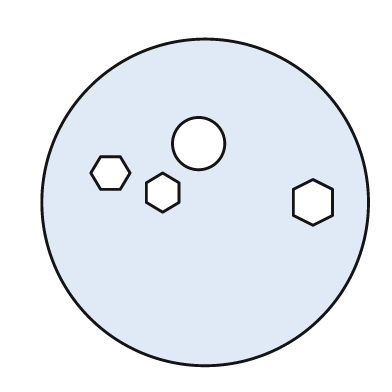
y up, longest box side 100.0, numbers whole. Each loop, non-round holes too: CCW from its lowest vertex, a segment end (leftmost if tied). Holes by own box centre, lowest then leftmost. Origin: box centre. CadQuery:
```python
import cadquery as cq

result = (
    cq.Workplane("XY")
    .moveTo(0.0, 0.0)
    .circle(50.0)
    .moveTo(33.0, -7.0)
    .lineTo(39.0, -4.0)
    .lineTo(39.0, 4.0)
    .lineTo(33.0, 7.0)
    .lineTo(27.0, 4.0)
    .lineTo(27.0, -4.0)
    .close()
    .moveTo(-13.0, -3.0)
    .lineTo(-8.0, 0.0)
    .lineTo(-8.0, 6.0)
    .lineTo(-13.0, 9.0)
    .lineTo(-18.0, 6.0)
    .lineTo(-18.0, 0.0)
    .close()
    .moveTo(-32.0, 4.0)
    .lineTo(-26.0, 4.0)
    .lineTo(-23.0, 9.0)
    .lineTo(-26.0, 14.0)
    .lineTo(-32.0, 14.0)
    .lineTo(-35.0, 9.0)
    .close()
    .moveTo(-2.0, 18.0)
    .circle(8.0)
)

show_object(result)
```